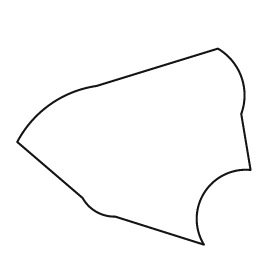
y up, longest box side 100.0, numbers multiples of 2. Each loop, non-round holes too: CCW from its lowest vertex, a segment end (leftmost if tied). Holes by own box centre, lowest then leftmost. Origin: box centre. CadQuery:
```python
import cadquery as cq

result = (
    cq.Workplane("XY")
    .moveTo(30.0, -42.0)
    .threePointArc((30.0, -20.0), (50.0, -10.0))
    .lineTo(46.0, 14.0)
    .threePointArc((46.0, 30.0), (36.0, 42.0))
    .lineTo(-16.0, 26.0)
    .threePointArc((-36.0, 18.0), (-50.0, 2.0))
    .lineTo(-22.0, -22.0)
    .threePointArc((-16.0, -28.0), (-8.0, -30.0))
    .close()
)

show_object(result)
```